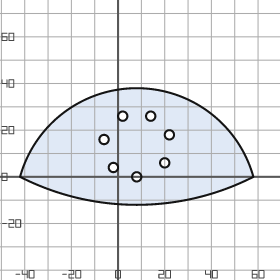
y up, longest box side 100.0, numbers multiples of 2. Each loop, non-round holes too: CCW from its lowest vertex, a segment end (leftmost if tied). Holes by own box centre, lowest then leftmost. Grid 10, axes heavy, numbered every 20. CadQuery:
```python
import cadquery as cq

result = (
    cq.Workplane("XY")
    .moveTo(-42.0, 0.0)
    .threePointArc((8.0, -12.0), (58.0, 0.0))
    .threePointArc((8.0, 38.0), (-42.0, 0.0))
    .close()
    .moveTo(8.0, 0.0)
    .circle(2.0)
    .moveTo(-2.0, 4.0)
    .circle(2.0)
    .moveTo(20.0, 6.0)
    .circle(2.0)
    .moveTo(-6.0, 16.0)
    .circle(2.0)
    .moveTo(22.0, 18.0)
    .circle(2.0)
    .moveTo(2.0, 26.0)
    .circle(2.0)
    .moveTo(14.0, 26.0)
    .circle(2.0)
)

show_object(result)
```